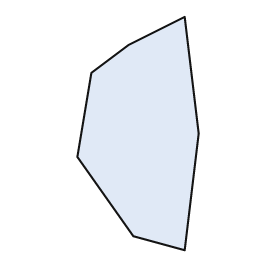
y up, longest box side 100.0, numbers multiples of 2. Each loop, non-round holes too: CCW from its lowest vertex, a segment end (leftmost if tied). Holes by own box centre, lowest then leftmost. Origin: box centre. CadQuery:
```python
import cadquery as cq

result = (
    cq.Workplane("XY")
    .moveTo(20.0, -50.0)
    .lineTo(26.0, 0.0)
    .lineTo(20.0, 50.0)
    .lineTo(-4.0, 38.0)
    .lineTo(-20.0, 26.0)
    .lineTo(-26.0, -10.0)
    .lineTo(-2.0, -44.0)
    .close()
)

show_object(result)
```